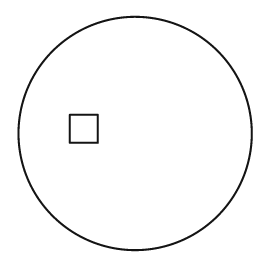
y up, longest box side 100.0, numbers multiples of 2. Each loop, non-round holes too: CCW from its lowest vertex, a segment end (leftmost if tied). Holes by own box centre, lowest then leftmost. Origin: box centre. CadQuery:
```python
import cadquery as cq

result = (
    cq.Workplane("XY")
    .moveTo(0.0, 0.0)
    .circle(50.0)
    .moveTo(-28.0, -4.0)
    .lineTo(-16.0, -4.0)
    .lineTo(-16.0, 8.0)
    .lineTo(-28.0, 8.0)
    .close()
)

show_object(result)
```